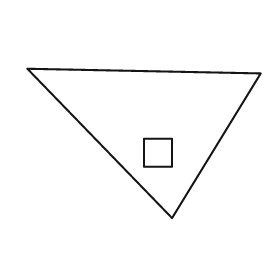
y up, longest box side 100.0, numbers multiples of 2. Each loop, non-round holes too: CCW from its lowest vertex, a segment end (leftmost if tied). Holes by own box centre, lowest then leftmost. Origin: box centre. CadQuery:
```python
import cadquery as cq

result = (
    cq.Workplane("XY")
    .moveTo(12.0, -32.0)
    .lineTo(50.0, 30.0)
    .lineTo(-50.0, 32.0)
    .close()
    .moveTo(0.0, -10.0)
    .lineTo(12.0, -10.0)
    .lineTo(12.0, 2.0)
    .lineTo(0.0, 2.0)
    .close()
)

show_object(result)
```